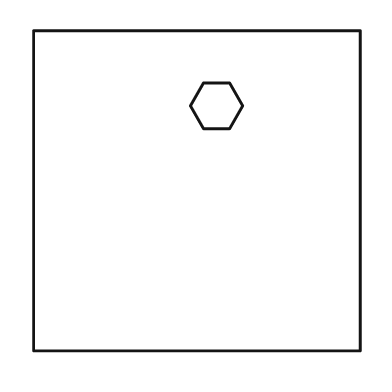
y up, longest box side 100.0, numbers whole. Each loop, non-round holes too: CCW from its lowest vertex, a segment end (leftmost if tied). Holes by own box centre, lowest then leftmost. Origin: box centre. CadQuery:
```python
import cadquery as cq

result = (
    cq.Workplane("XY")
    .moveTo(-50.0, -49.0)
    .lineTo(50.0, -49.0)
    .lineTo(50.0, 49.0)
    .lineTo(-50.0, 49.0)
    .close()
    .moveTo(2.0, 19.0)
    .lineTo(10.0, 19.0)
    .lineTo(14.0, 26.0)
    .lineTo(10.0, 33.0)
    .lineTo(2.0, 33.0)
    .lineTo(-2.0, 26.0)
    .close()
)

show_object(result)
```